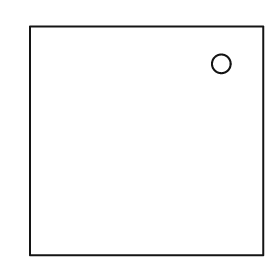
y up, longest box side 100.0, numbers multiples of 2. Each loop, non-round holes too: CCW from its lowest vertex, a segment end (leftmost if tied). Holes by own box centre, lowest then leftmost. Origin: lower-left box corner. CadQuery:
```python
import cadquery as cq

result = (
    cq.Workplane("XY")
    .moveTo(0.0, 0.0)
    .lineTo(100.0, 0.0)
    .lineTo(100.0, 98.0)
    .lineTo(0.0, 98.0)
    .close()
    .moveTo(82.0, 82.0)
    .circle(4.0)
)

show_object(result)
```